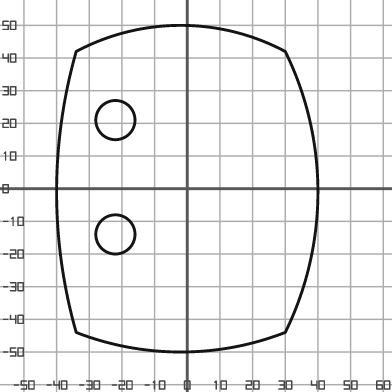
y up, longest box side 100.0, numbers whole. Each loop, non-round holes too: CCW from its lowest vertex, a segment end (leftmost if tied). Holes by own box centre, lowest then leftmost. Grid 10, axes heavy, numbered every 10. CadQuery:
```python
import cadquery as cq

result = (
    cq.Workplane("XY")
    .moveTo(-34.0, -44.0)
    .threePointArc((-2.0, -50.0), (30.0, -44.0))
    .threePointArc((40.0, -1.0), (30.0, 42.0))
    .threePointArc((-2.0, 50.0), (-34.0, 42.0))
    .threePointArc((-40.0, -1.0), (-34.0, -44.0))
    .close()
    .moveTo(-22.0, -14.0)
    .circle(6.0)
    .moveTo(-22.0, 21.0)
    .circle(6.0)
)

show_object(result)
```